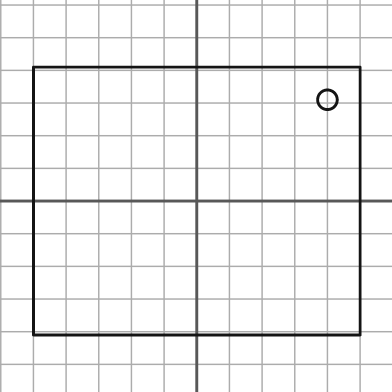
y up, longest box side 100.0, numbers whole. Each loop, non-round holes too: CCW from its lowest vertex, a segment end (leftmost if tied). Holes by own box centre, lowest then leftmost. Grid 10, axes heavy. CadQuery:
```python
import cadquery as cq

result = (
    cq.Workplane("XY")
    .moveTo(-50.0, -41.0)
    .lineTo(50.0, -41.0)
    .lineTo(50.0, 41.0)
    .lineTo(-50.0, 41.0)
    .close()
    .moveTo(40.0, 31.0)
    .circle(3.0)
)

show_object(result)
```